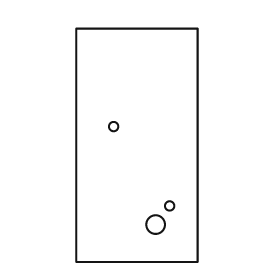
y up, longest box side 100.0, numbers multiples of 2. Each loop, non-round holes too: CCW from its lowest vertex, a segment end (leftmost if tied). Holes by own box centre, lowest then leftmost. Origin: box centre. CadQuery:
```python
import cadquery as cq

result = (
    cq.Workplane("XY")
    .moveTo(-26.0, -50.0)
    .lineTo(26.0, -50.0)
    .lineTo(26.0, 50.0)
    .lineTo(-26.0, 50.0)
    .close()
    .moveTo(8.0, -34.0)
    .circle(4.0)
    .moveTo(14.0, -26.0)
    .circle(2.0)
    .moveTo(-10.0, 8.0)
    .circle(2.0)
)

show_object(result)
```